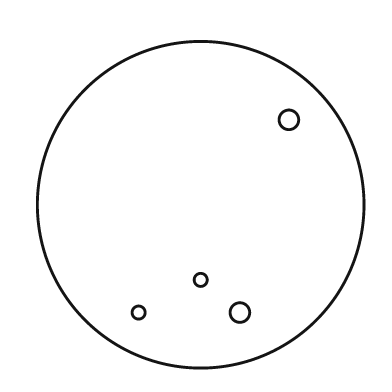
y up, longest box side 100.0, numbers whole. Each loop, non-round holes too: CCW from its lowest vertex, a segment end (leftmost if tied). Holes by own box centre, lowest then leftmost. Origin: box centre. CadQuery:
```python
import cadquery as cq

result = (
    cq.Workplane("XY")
    .moveTo(0.0, 0.0)
    .circle(50.0)
    .moveTo(-19.0, -33.0)
    .circle(2.0)
    .moveTo(12.0, -33.0)
    .circle(3.0)
    .moveTo(0.0, -23.0)
    .circle(2.0)
    .moveTo(27.0, 26.0)
    .circle(3.0)
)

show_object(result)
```